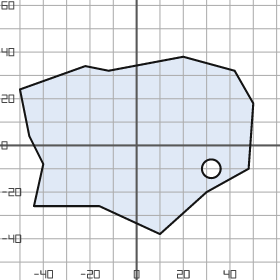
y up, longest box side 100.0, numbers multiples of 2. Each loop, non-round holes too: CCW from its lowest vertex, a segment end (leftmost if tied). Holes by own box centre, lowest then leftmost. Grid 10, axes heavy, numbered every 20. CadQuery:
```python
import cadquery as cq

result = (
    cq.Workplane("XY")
    .moveTo(10.0, -38.0)
    .lineTo(30.0, -20.0)
    .lineTo(48.0, -10.0)
    .lineTo(50.0, 18.0)
    .lineTo(42.0, 32.0)
    .lineTo(20.0, 38.0)
    .lineTo(-12.0, 32.0)
    .lineTo(-22.0, 34.0)
    .lineTo(-50.0, 24.0)
    .lineTo(-46.0, 4.0)
    .lineTo(-40.0, -8.0)
    .lineTo(-44.0, -26.0)
    .lineTo(-16.0, -26.0)
    .close()
    .moveTo(32.0, -10.0)
    .circle(4.0)
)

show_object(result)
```